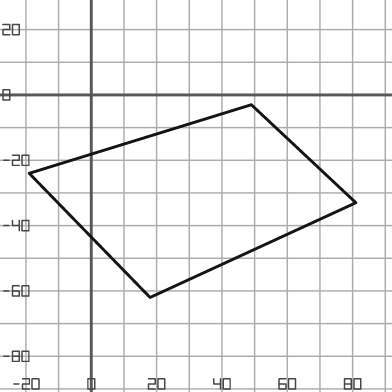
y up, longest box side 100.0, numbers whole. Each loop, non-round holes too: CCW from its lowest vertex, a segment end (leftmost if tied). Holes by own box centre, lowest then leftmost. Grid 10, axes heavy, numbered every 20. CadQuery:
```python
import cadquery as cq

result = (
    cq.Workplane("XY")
    .moveTo(18.0, -62.0)
    .lineTo(81.0, -33.0)
    .lineTo(49.0, -3.0)
    .lineTo(-19.0, -24.0)
    .close()
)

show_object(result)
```